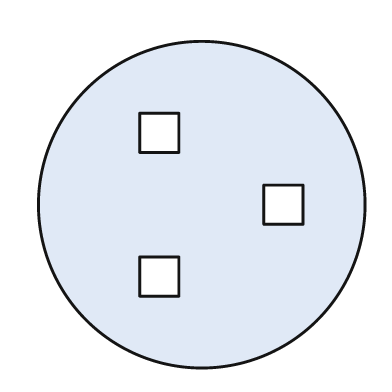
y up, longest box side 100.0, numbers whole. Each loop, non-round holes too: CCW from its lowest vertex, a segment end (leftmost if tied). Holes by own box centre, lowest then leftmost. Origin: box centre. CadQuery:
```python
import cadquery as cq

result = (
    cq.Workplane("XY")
    .moveTo(0.0, 0.0)
    .circle(50.0)
    .moveTo(-19.0, -28.0)
    .lineTo(-7.0, -28.0)
    .lineTo(-7.0, -16.0)
    .lineTo(-19.0, -16.0)
    .close()
    .moveTo(19.0, -6.0)
    .lineTo(31.0, -6.0)
    .lineTo(31.0, 6.0)
    .lineTo(19.0, 6.0)
    .close()
    .moveTo(-19.0, 16.0)
    .lineTo(-7.0, 16.0)
    .lineTo(-7.0, 28.0)
    .lineTo(-19.0, 28.0)
    .close()
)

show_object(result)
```